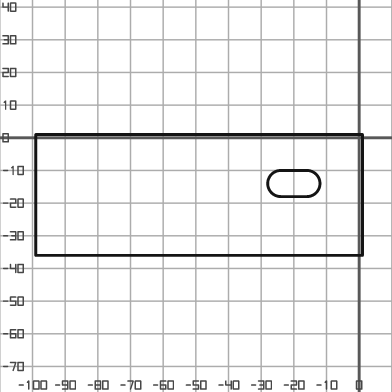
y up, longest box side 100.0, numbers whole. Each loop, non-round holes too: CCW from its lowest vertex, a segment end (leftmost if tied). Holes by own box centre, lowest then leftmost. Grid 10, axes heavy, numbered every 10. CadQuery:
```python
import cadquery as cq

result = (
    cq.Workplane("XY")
    .moveTo(-99.0, -36.0)
    .lineTo(1.0, -36.0)
    .lineTo(1.0, 1.0)
    .lineTo(-99.0, 1.0)
    .close()
    .moveTo(-24.0, -18.0)
    .lineTo(-16.0, -18.0)
    .threePointArc((-12.0, -14.0), (-16.0, -10.0))
    .lineTo(-24.0, -10.0)
    .threePointArc((-28.0, -14.0), (-24.0, -18.0))
    .close()
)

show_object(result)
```